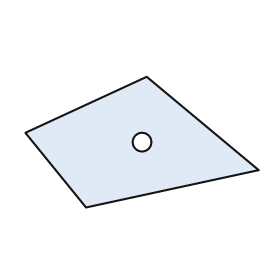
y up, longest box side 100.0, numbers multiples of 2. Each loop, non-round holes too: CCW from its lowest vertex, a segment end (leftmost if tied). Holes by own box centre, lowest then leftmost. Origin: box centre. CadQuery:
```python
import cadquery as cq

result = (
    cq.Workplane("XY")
    .moveTo(-24.0, -28.0)
    .lineTo(50.0, -12.0)
    .lineTo(2.0, 28.0)
    .lineTo(-50.0, 4.0)
    .close()
    .moveTo(0.0, 0.0)
    .circle(4.0)
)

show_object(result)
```